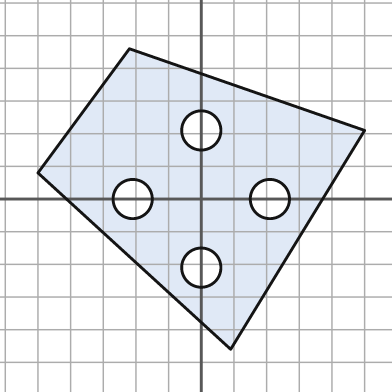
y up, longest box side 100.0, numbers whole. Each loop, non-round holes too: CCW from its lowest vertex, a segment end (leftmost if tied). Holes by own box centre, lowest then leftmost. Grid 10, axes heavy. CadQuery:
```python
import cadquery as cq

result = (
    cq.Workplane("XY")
    .moveTo(9.0, -46.0)
    .lineTo(50.0, 21.0)
    .lineTo(-22.0, 46.0)
    .lineTo(-50.0, 8.0)
    .close()
    .moveTo(0.0, -21.0)
    .circle(6.0)
    .moveTo(-21.0, 0.0)
    .circle(6.0)
    .moveTo(21.0, 0.0)
    .circle(6.0)
    .moveTo(0.0, 21.0)
    .circle(6.0)
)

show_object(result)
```